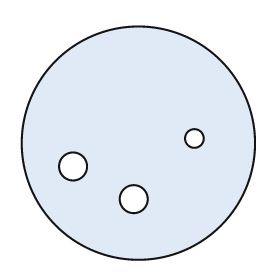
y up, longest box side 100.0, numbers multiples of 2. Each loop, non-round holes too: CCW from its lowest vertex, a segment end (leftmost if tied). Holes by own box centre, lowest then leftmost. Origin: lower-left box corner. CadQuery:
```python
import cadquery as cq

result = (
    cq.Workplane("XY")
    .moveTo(50.0, 50.0)
    .circle(50.0)
    .moveTo(48.0, 26.0)
    .circle(6.0)
    .moveTo(22.0, 40.0)
    .circle(6.0)
    .moveTo(74.0, 52.0)
    .circle(4.0)
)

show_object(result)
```